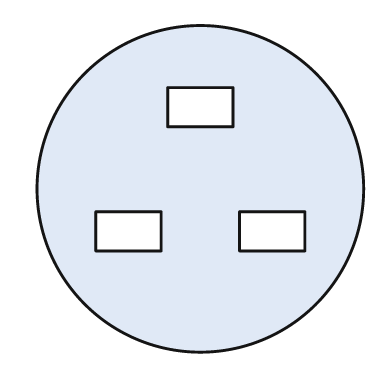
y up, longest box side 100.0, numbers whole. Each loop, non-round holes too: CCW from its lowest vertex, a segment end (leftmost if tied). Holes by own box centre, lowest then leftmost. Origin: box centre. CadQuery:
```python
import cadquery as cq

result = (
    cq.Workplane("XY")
    .moveTo(0.0, 0.0)
    .circle(50.0)
    .moveTo(-32.0, -19.0)
    .lineTo(-12.0, -19.0)
    .lineTo(-12.0, -7.0)
    .lineTo(-32.0, -7.0)
    .close()
    .moveTo(12.0, -19.0)
    .lineTo(32.0, -19.0)
    .lineTo(32.0, -7.0)
    .lineTo(12.0, -7.0)
    .close()
    .moveTo(-10.0, 19.0)
    .lineTo(10.0, 19.0)
    .lineTo(10.0, 31.0)
    .lineTo(-10.0, 31.0)
    .close()
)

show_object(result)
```